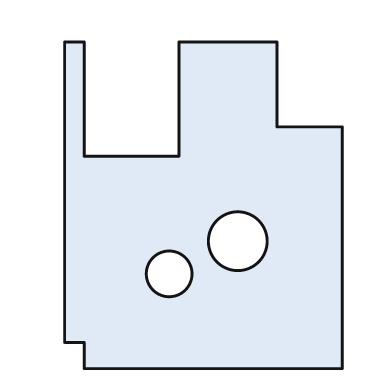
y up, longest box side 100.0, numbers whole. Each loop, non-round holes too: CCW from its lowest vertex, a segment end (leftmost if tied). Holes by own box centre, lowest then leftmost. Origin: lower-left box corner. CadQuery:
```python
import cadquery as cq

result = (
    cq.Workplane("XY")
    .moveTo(6.0, 0.0)
    .lineTo(85.0, 0.0)
    .lineTo(85.0, 74.0)
    .lineTo(65.0, 74.0)
    .lineTo(65.0, 100.0)
    .lineTo(35.0, 100.0)
    .lineTo(35.0, 65.0)
    .lineTo(6.0, 65.0)
    .lineTo(6.0, 100.0)
    .lineTo(0.0, 100.0)
    .lineTo(0.0, 8.0)
    .lineTo(6.0, 8.0)
    .close()
    .moveTo(32.0, 29.0)
    .circle(7.0)
    .moveTo(53.0, 39.0)
    .circle(9.0)
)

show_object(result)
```